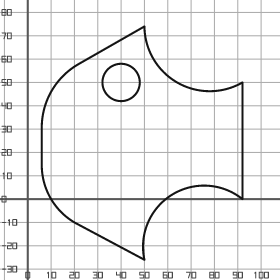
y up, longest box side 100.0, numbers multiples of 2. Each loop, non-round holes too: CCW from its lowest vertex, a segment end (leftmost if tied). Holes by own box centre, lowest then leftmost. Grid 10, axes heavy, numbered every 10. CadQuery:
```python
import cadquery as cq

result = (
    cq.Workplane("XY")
    .moveTo(50.0, -26.0)
    .threePointArc((62.0, 2.0), (92.0, 0.0))
    .lineTo(92.0, 50.0)
    .threePointArc((64.0, 50.0), (50.0, 74.0))
    .lineTo(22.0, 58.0)
    .threePointArc((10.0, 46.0), (6.0, 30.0))
    .lineTo(6.0, 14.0)
    .threePointArc((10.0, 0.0), (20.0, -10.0))
    .close()
    .moveTo(40.0, 50.0)
    .circle(8.0)
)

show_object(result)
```